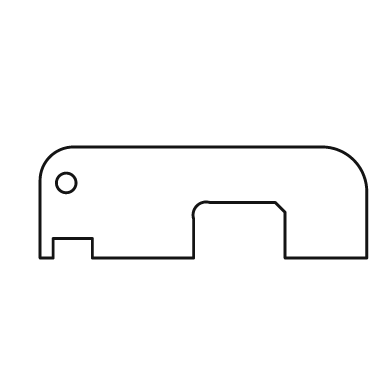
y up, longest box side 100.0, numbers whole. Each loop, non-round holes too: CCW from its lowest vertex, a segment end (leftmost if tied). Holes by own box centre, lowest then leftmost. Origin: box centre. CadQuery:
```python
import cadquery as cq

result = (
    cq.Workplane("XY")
    .moveTo(-50.0, -17.0)
    .lineTo(-46.0, -17.0)
    .lineTo(-46.0, -11.0)
    .lineTo(-34.0, -11.0)
    .lineTo(-34.0, -17.0)
    .lineTo(-3.0, -17.0)
    .lineTo(-3.0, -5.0)
    .threePointArc((-2.0, -1.0), (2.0, 0.0))
    .lineTo(22.0, 0.0)
    .lineTo(25.0, -3.0)
    .lineTo(25.0, -17.0)
    .lineTo(50.0, -17.0)
    .lineTo(50.0, 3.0)
    .threePointArc((46.0, 13.0), (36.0, 17.0))
    .lineTo(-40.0, 17.0)
    .threePointArc((-47.0, 14.0), (-50.0, 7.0))
    .close()
    .moveTo(-42.0, 6.0)
    .circle(3.0)
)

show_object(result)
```